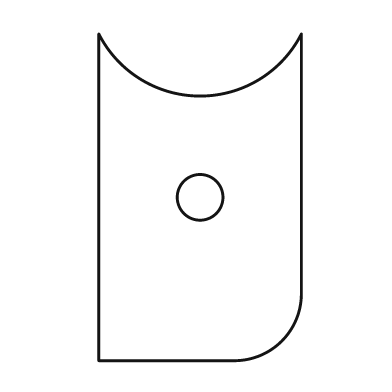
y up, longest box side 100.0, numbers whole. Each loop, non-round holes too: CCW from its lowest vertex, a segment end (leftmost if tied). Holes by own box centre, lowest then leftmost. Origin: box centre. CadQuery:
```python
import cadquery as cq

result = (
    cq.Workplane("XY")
    .moveTo(-31.0, -50.0)
    .lineTo(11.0, -50.0)
    .threePointArc((25.0, -44.0), (31.0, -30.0))
    .lineTo(31.0, 50.0)
    .threePointArc((0.0, 31.0), (-31.0, 50.0))
    .close()
    .moveTo(0.0, 0.0)
    .circle(7.0)
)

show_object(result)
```